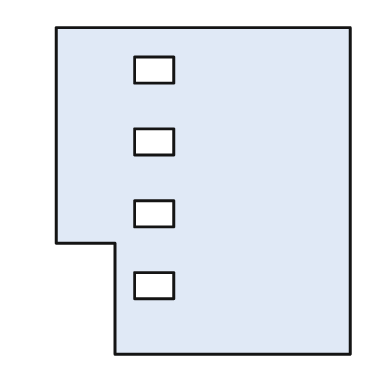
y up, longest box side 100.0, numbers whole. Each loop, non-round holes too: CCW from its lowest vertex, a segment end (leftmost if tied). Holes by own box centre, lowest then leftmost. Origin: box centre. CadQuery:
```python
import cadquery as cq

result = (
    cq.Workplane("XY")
    .moveTo(-27.0, -50.0)
    .lineTo(45.0, -50.0)
    .lineTo(45.0, 50.0)
    .lineTo(-45.0, 50.0)
    .lineTo(-45.0, -16.0)
    .lineTo(-27.0, -16.0)
    .close()
    .moveTo(-21.0, -33.0)
    .lineTo(-9.0, -33.0)
    .lineTo(-9.0, -25.0)
    .lineTo(-21.0, -25.0)
    .close()
    .moveTo(-21.0, -11.0)
    .lineTo(-9.0, -11.0)
    .lineTo(-9.0, -3.0)
    .lineTo(-21.0, -3.0)
    .close()
    .moveTo(-21.0, 11.0)
    .lineTo(-9.0, 11.0)
    .lineTo(-9.0, 19.0)
    .lineTo(-21.0, 19.0)
    .close()
    .moveTo(-21.0, 33.0)
    .lineTo(-9.0, 33.0)
    .lineTo(-9.0, 41.0)
    .lineTo(-21.0, 41.0)
    .close()
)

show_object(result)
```